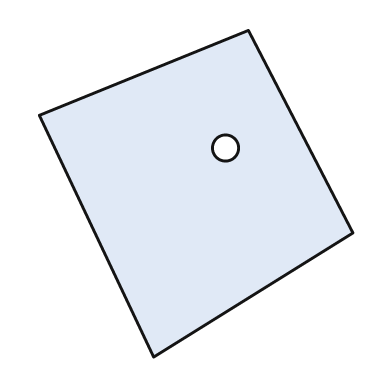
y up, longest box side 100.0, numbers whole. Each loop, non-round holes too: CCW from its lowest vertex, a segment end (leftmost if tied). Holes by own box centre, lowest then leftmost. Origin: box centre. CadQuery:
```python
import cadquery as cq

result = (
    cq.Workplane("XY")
    .moveTo(-13.0, -50.0)
    .lineTo(48.0, -12.0)
    .lineTo(16.0, 50.0)
    .lineTo(-48.0, 24.0)
    .close()
    .moveTo(9.0, 14.0)
    .circle(4.0)
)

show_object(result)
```